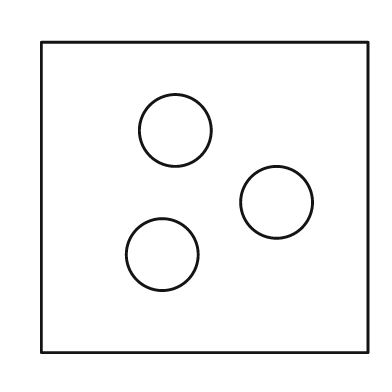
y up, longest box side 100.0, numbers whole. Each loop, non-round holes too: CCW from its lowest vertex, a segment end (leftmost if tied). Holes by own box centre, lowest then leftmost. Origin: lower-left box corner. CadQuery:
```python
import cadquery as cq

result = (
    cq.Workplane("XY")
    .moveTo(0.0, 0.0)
    .lineTo(100.0, 0.0)
    .lineTo(100.0, 95.0)
    .lineTo(0.0, 95.0)
    .close()
    .moveTo(37.0, 30.0)
    .circle(11.0)
    .moveTo(72.0, 46.0)
    .circle(11.0)
    .moveTo(41.0, 68.0)
    .circle(11.0)
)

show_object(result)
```